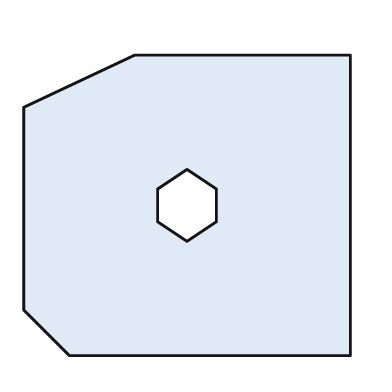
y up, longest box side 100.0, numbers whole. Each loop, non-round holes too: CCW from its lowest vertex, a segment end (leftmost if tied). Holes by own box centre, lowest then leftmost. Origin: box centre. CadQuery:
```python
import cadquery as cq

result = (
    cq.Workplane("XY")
    .moveTo(-36.0, -46.0)
    .lineTo(50.0, -46.0)
    .lineTo(50.0, 46.0)
    .lineTo(-16.0, 46.0)
    .lineTo(-50.0, 30.0)
    .lineTo(-50.0, -32.0)
    .close()
    .moveTo(0.0, -11.0)
    .lineTo(9.0, -5.0)
    .lineTo(9.0, 5.0)
    .lineTo(0.0, 11.0)
    .lineTo(-9.0, 5.0)
    .lineTo(-9.0, -5.0)
    .close()
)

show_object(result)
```